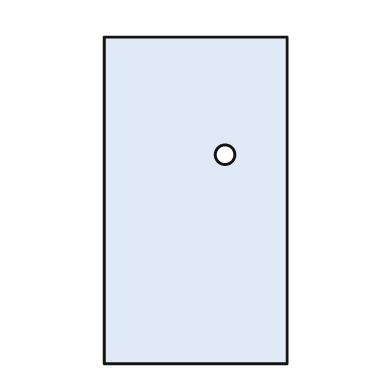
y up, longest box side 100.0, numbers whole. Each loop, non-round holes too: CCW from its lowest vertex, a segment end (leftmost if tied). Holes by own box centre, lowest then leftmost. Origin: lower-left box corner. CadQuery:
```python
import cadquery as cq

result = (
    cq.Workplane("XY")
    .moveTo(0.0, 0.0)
    .lineTo(56.0, 0.0)
    .lineTo(56.0, 100.0)
    .lineTo(0.0, 100.0)
    .close()
    .moveTo(37.0, 64.0)
    .circle(3.0)
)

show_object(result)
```